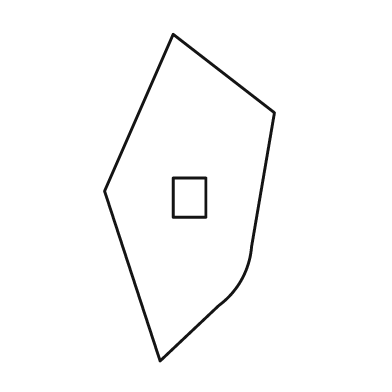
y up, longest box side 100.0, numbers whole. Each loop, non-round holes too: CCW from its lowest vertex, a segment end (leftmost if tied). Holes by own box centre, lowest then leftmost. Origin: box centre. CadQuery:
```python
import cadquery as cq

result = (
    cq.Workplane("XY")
    .moveTo(-9.0, -50.0)
    .lineTo(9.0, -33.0)
    .threePointArc((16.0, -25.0), (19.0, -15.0))
    .lineTo(26.0, 26.0)
    .lineTo(-5.0, 50.0)
    .lineTo(-26.0, 2.0)
    .close()
    .moveTo(-5.0, -6.0)
    .lineTo(5.0, -6.0)
    .lineTo(5.0, 6.0)
    .lineTo(-5.0, 6.0)
    .close()
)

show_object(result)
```